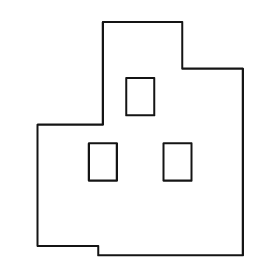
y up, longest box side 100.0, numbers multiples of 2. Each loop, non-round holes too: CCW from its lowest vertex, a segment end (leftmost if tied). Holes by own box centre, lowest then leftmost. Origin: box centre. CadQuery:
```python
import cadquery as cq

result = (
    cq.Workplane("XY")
    .moveTo(-18.0, -50.0)
    .lineTo(44.0, -50.0)
    .lineTo(44.0, 30.0)
    .lineTo(18.0, 30.0)
    .lineTo(18.0, 50.0)
    .lineTo(-16.0, 50.0)
    .lineTo(-16.0, 6.0)
    .lineTo(-44.0, 6.0)
    .lineTo(-44.0, -46.0)
    .lineTo(-18.0, -46.0)
    .close()
    .moveTo(-22.0, -18.0)
    .lineTo(-10.0, -18.0)
    .lineTo(-10.0, -2.0)
    .lineTo(-22.0, -2.0)
    .close()
    .moveTo(10.0, -18.0)
    .lineTo(22.0, -18.0)
    .lineTo(22.0, -2.0)
    .lineTo(10.0, -2.0)
    .close()
    .moveTo(-6.0, 10.0)
    .lineTo(6.0, 10.0)
    .lineTo(6.0, 26.0)
    .lineTo(-6.0, 26.0)
    .close()
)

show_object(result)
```